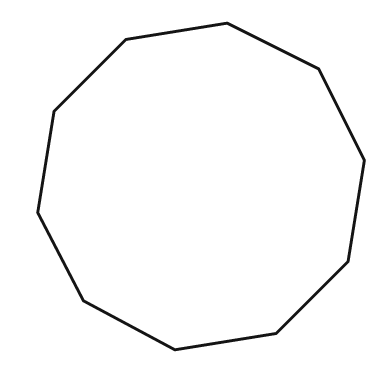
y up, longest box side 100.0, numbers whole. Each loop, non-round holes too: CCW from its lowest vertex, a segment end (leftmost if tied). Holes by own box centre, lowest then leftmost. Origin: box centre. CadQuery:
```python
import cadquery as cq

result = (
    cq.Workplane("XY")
    .moveTo(-8.0, -50.0)
    .lineTo(23.0, -45.0)
    .lineTo(45.0, -23.0)
    .lineTo(50.0, 8.0)
    .lineTo(36.0, 36.0)
    .lineTo(8.0, 50.0)
    .lineTo(-23.0, 45.0)
    .lineTo(-45.0, 23.0)
    .lineTo(-50.0, -8.0)
    .lineTo(-36.0, -35.0)
    .close()
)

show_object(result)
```